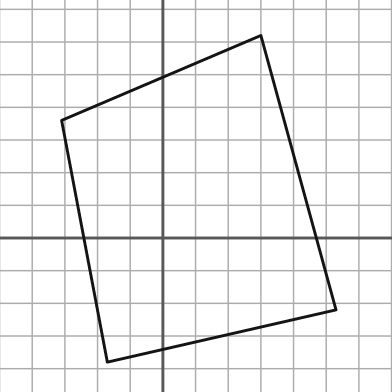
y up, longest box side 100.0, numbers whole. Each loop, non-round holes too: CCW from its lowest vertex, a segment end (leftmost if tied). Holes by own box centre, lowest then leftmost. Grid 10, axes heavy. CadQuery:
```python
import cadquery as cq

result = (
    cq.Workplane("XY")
    .moveTo(-17.0, -38.0)
    .lineTo(53.0, -22.0)
    .lineTo(30.0, 62.0)
    .lineTo(-31.0, 36.0)
    .close()
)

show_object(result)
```